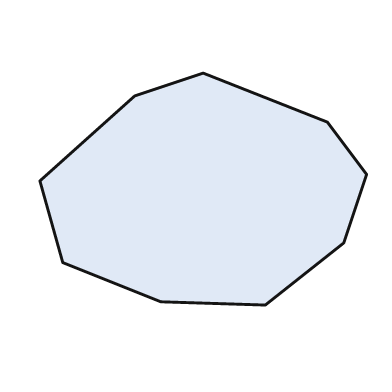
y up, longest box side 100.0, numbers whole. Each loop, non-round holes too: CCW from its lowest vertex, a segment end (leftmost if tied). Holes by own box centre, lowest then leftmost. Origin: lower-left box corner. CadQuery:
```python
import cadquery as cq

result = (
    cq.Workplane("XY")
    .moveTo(69.0, 0.0)
    .lineTo(93.0, 19.0)
    .lineTo(100.0, 40.0)
    .lineTo(88.0, 56.0)
    .lineTo(50.0, 71.0)
    .lineTo(29.0, 64.0)
    .lineTo(0.0, 38.0)
    .lineTo(7.0, 13.0)
    .lineTo(37.0, 1.0)
    .close()
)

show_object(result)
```